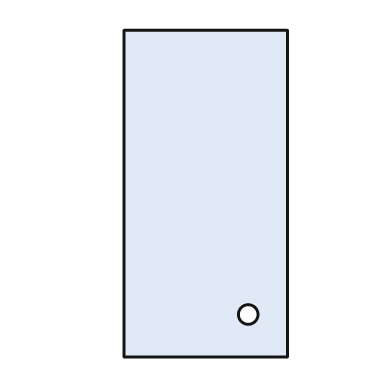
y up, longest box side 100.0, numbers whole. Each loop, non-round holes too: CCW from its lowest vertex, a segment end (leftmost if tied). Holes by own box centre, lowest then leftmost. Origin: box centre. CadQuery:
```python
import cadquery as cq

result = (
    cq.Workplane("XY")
    .moveTo(-25.0, -50.0)
    .lineTo(25.0, -50.0)
    .lineTo(25.0, 50.0)
    .lineTo(-25.0, 50.0)
    .close()
    .moveTo(13.0, -37.0)
    .circle(3.0)
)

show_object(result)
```